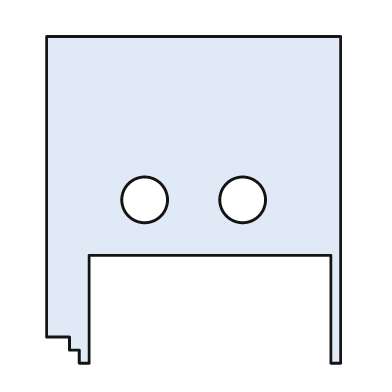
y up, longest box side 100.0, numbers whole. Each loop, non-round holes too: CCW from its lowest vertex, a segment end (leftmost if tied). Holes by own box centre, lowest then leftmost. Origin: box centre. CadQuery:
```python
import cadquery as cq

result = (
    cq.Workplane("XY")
    .moveTo(-35.0, -50.0)
    .lineTo(-32.0, -50.0)
    .lineTo(-32.0, -17.0)
    .lineTo(42.0, -17.0)
    .lineTo(42.0, -50.0)
    .lineTo(45.0, -50.0)
    .lineTo(45.0, 50.0)
    .lineTo(-45.0, 50.0)
    .lineTo(-45.0, -42.0)
    .lineTo(-38.0, -42.0)
    .lineTo(-38.0, -46.0)
    .lineTo(-35.0, -46.0)
    .close()
    .moveTo(-15.0, 0.0)
    .circle(7.0)
    .moveTo(15.0, 0.0)
    .circle(7.0)
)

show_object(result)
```